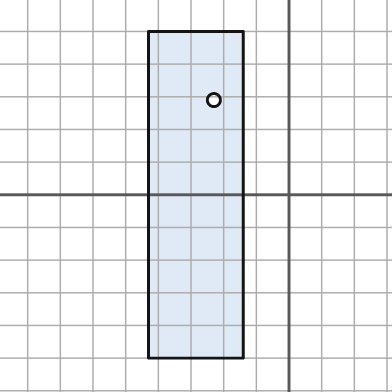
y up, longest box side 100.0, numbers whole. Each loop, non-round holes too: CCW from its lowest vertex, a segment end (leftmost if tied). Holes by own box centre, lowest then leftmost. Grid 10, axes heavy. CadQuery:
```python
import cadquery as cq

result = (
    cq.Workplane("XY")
    .moveTo(-43.0, -50.0)
    .lineTo(-14.0, -50.0)
    .lineTo(-14.0, 50.0)
    .lineTo(-43.0, 50.0)
    .close()
    .moveTo(-23.0, 29.0)
    .circle(2.0)
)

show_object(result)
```